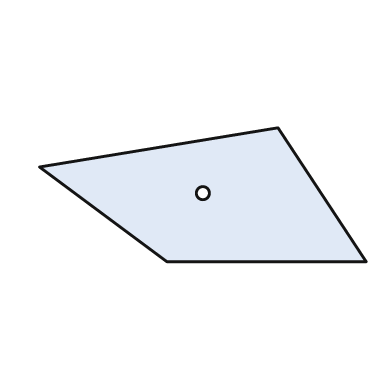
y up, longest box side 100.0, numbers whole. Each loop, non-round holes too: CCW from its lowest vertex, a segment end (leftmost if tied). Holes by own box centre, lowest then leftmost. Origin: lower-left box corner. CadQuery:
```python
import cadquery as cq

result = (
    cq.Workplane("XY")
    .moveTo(39.0, 0.0)
    .lineTo(100.0, 0.0)
    .lineTo(73.0, 41.0)
    .lineTo(0.0, 29.0)
    .close()
    .moveTo(50.0, 21.0)
    .circle(2.0)
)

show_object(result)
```